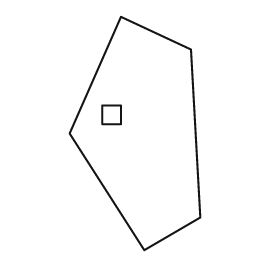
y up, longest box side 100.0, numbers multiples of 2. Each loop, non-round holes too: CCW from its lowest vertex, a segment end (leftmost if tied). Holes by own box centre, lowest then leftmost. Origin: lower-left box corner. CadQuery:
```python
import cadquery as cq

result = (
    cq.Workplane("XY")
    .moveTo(32.0, 0.0)
    .lineTo(56.0, 14.0)
    .lineTo(52.0, 86.0)
    .lineTo(22.0, 100.0)
    .lineTo(0.0, 50.0)
    .close()
    .moveTo(14.0, 54.0)
    .lineTo(22.0, 54.0)
    .lineTo(22.0, 62.0)
    .lineTo(14.0, 62.0)
    .close()
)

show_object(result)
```